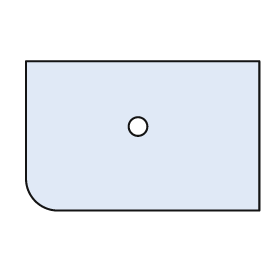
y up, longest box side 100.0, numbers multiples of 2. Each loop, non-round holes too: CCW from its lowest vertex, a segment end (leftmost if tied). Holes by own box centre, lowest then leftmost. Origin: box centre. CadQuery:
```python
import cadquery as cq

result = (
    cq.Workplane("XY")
    .moveTo(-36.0, -32.0)
    .lineTo(50.0, -32.0)
    .lineTo(50.0, 32.0)
    .lineTo(-50.0, 32.0)
    .lineTo(-50.0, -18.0)
    .threePointArc((-46.0, -28.0), (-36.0, -32.0))
    .close()
    .moveTo(-2.0, 4.0)
    .circle(4.0)
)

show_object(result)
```